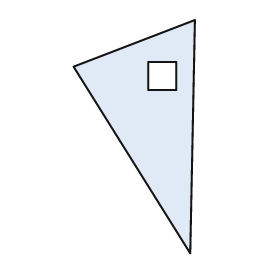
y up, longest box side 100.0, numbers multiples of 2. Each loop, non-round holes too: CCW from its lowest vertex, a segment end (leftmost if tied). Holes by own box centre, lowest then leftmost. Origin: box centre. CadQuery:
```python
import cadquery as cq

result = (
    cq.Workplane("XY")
    .moveTo(24.0, -50.0)
    .lineTo(26.0, 50.0)
    .lineTo(-26.0, 30.0)
    .close()
    .moveTo(6.0, 20.0)
    .lineTo(18.0, 20.0)
    .lineTo(18.0, 32.0)
    .lineTo(6.0, 32.0)
    .close()
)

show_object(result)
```